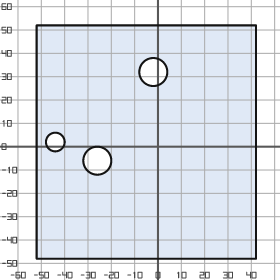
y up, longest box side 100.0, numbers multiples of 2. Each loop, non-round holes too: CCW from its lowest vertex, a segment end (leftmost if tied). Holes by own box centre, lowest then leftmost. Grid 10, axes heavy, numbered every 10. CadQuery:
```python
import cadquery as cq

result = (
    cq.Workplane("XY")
    .moveTo(-52.0, -48.0)
    .lineTo(42.0, -48.0)
    .lineTo(42.0, 52.0)
    .lineTo(-52.0, 52.0)
    .close()
    .moveTo(-26.0, -6.0)
    .circle(6.0)
    .moveTo(-44.0, 2.0)
    .circle(4.0)
    .moveTo(-2.0, 32.0)
    .circle(6.0)
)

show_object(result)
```